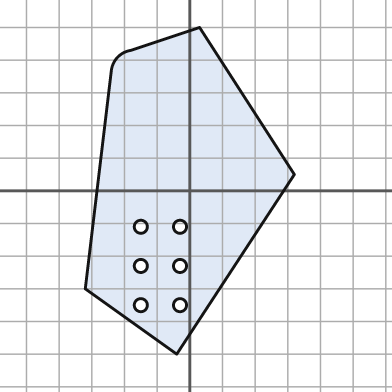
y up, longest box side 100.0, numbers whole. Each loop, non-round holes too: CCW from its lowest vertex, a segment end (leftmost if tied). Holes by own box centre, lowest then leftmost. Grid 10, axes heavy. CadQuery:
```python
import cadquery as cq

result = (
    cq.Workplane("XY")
    .moveTo(-4.0, -50.0)
    .lineTo(32.0, 5.0)
    .lineTo(3.0, 50.0)
    .lineTo(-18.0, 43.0)
    .threePointArc((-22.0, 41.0), (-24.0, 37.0))
    .lineTo(-32.0, -30.0)
    .close()
    .moveTo(-15.0, -35.0)
    .circle(2.0)
    .moveTo(-3.0, -35.0)
    .circle(2.0)
    .moveTo(-15.0, -23.0)
    .circle(2.0)
    .moveTo(-3.0, -23.0)
    .circle(2.0)
    .moveTo(-15.0, -11.0)
    .circle(2.0)
    .moveTo(-3.0, -11.0)
    .circle(2.0)
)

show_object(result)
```